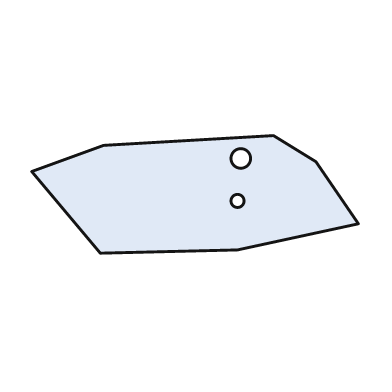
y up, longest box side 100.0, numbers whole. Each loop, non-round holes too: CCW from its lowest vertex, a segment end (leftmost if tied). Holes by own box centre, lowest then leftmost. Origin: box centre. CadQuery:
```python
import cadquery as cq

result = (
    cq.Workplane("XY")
    .moveTo(-29.0, -18.0)
    .lineTo(13.0, -17.0)
    .lineTo(50.0, -9.0)
    .lineTo(37.0, 10.0)
    .lineTo(24.0, 18.0)
    .lineTo(-28.0, 15.0)
    .lineTo(-50.0, 7.0)
    .close()
    .moveTo(13.0, -2.0)
    .circle(2.0)
    .moveTo(14.0, 11.0)
    .circle(3.0)
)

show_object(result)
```